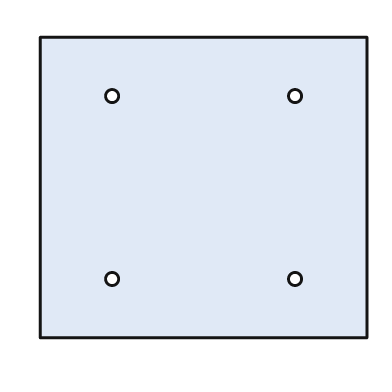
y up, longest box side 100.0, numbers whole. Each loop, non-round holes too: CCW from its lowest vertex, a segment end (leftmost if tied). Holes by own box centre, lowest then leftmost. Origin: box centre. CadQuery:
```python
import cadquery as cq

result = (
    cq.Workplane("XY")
    .moveTo(-50.0, -46.0)
    .lineTo(50.0, -46.0)
    .lineTo(50.0, 46.0)
    .lineTo(-50.0, 46.0)
    .close()
    .moveTo(-28.0, -28.0)
    .circle(2.0)
    .moveTo(28.0, -28.0)
    .circle(2.0)
    .moveTo(-28.0, 28.0)
    .circle(2.0)
    .moveTo(28.0, 28.0)
    .circle(2.0)
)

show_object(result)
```